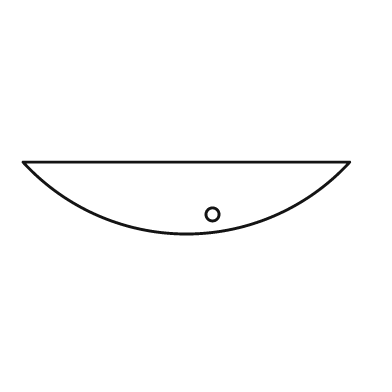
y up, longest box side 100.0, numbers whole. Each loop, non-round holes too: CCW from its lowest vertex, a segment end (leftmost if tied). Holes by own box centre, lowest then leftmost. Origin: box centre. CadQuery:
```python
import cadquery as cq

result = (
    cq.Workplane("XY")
    .moveTo(-50.0, 11.0)
    .threePointArc((0.0, -11.0), (50.0, 11.0))
    .close()
    .moveTo(8.0, -5.0)
    .circle(2.0)
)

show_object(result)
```